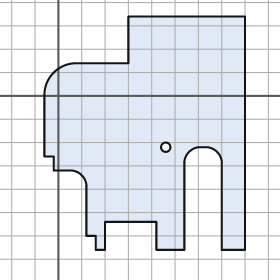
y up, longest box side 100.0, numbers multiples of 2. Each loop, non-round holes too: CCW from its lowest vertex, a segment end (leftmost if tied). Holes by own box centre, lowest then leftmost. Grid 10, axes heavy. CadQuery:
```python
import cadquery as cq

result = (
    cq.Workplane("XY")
    .moveTo(16.0, -66.0)
    .lineTo(20.0, -66.0)
    .lineTo(20.0, -54.0)
    .lineTo(42.0, -54.0)
    .lineTo(42.0, -66.0)
    .lineTo(54.0, -66.0)
    .lineTo(54.0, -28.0)
    .threePointArc((56.0, -24.0), (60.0, -22.0))
    .lineTo(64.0, -22.0)
    .threePointArc((68.0, -24.0), (70.0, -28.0))
    .lineTo(70.0, -66.0)
    .lineTo(80.0, -66.0)
    .lineTo(80.0, 34.0)
    .lineTo(30.0, 34.0)
    .lineTo(30.0, 14.0)
    .lineTo(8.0, 14.0)
    .threePointArc((-2.0, 10.0), (-6.0, 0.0))
    .lineTo(-6.0, -26.0)
    .lineTo(-2.0, -26.0)
    .lineTo(-2.0, -32.0)
    .lineTo(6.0, -32.0)
    .threePointArc((10.0, -34.0), (12.0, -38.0))
    .lineTo(12.0, -60.0)
    .lineTo(16.0, -60.0)
    .close()
    .moveTo(46.0, -22.0)
    .circle(2.0)
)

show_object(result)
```